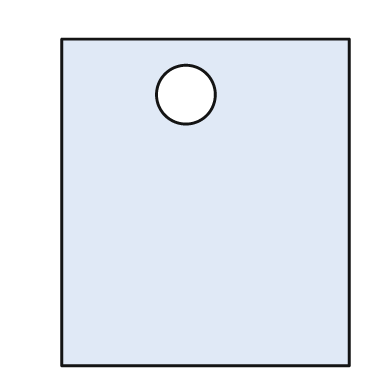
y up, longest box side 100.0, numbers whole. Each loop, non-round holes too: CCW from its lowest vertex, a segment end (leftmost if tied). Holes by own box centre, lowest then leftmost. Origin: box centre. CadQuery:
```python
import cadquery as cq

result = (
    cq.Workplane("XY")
    .moveTo(-44.0, -50.0)
    .lineTo(44.0, -50.0)
    .lineTo(44.0, 50.0)
    .lineTo(-44.0, 50.0)
    .close()
    .moveTo(-6.0, 33.0)
    .circle(9.0)
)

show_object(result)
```